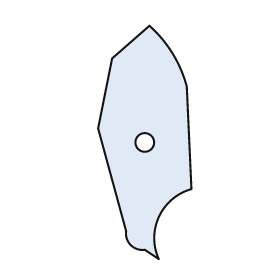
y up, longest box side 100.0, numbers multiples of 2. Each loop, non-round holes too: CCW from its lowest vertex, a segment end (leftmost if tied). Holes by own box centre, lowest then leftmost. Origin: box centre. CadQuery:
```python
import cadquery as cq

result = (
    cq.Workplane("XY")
    .moveTo(6.0, -50.0)
    .threePointArc((6.0, -32.0), (20.0, -20.0))
    .lineTo(18.0, 24.0)
    .threePointArc((12.0, 38.0), (2.0, 50.0))
    .lineTo(-14.0, 36.0)
    .lineTo(-20.0, 6.0)
    .lineTo(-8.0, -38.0)
    .threePointArc((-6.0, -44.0), (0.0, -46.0))
    .close()
    .moveTo(0.0, 0.0)
    .circle(4.0)
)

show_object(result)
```